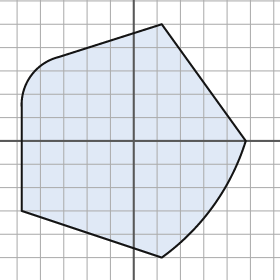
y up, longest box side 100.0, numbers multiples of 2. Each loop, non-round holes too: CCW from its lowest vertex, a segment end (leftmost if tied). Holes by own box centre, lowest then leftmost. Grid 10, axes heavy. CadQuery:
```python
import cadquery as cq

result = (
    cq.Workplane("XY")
    .moveTo(12.0, -50.0)
    .threePointArc((34.0, -28.0), (48.0, 0.0))
    .lineTo(12.0, 50.0)
    .lineTo(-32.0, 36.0)
    .threePointArc((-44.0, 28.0), (-48.0, 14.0))
    .lineTo(-48.0, -30.0)
    .close()
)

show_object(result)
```